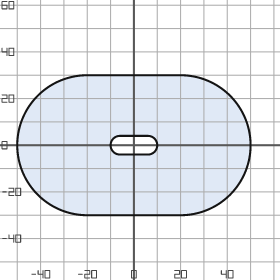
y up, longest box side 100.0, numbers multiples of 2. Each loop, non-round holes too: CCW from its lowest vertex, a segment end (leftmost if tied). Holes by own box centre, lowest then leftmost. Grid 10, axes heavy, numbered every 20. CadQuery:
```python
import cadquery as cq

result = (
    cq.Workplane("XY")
    .moveTo(-20.0, -30.0)
    .lineTo(20.0, -30.0)
    .threePointArc((50.0, 0.0), (20.0, 30.0))
    .lineTo(-20.0, 30.0)
    .threePointArc((-50.0, 0.0), (-20.0, -30.0))
    .close()
    .moveTo(-6.0, -4.0)
    .lineTo(6.0, -4.0)
    .threePointArc((10.0, 0.0), (6.0, 4.0))
    .lineTo(-6.0, 4.0)
    .threePointArc((-10.0, 0.0), (-6.0, -4.0))
    .close()
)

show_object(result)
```